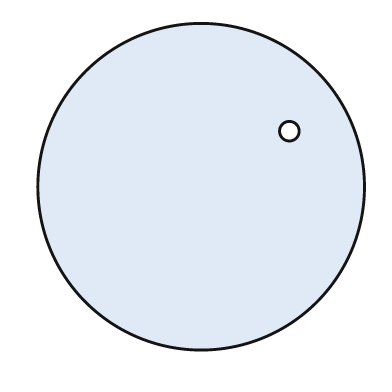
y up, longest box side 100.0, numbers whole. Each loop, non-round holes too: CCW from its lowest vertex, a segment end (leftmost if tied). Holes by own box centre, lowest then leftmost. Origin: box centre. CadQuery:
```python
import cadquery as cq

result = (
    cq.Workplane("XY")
    .moveTo(0.0, 0.0)
    .circle(50.0)
    .moveTo(27.0, 17.0)
    .circle(3.0)
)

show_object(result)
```